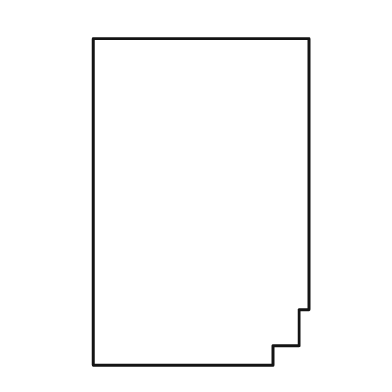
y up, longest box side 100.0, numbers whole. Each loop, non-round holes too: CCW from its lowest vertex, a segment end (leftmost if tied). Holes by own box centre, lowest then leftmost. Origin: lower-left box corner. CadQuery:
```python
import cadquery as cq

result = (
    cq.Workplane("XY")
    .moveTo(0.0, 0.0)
    .lineTo(55.0, 0.0)
    .lineTo(55.0, 6.0)
    .lineTo(63.0, 6.0)
    .lineTo(63.0, 17.0)
    .lineTo(66.0, 17.0)
    .lineTo(66.0, 100.0)
    .lineTo(0.0, 100.0)
    .close()
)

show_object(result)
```